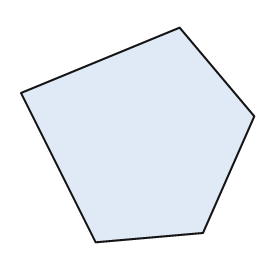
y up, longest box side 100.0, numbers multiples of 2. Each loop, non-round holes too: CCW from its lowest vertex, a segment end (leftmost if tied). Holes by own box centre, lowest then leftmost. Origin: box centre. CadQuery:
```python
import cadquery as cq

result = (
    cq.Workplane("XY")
    .moveTo(-18.0, -46.0)
    .lineTo(28.0, -42.0)
    .lineTo(50.0, 8.0)
    .lineTo(18.0, 46.0)
    .lineTo(-50.0, 18.0)
    .close()
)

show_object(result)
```